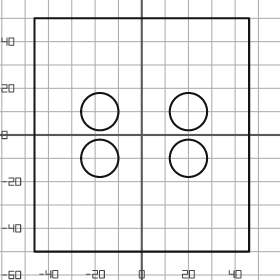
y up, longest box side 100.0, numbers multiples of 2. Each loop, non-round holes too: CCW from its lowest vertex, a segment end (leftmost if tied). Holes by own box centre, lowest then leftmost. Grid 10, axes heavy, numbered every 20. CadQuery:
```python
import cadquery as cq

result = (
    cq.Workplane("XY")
    .moveTo(-46.0, -50.0)
    .lineTo(46.0, -50.0)
    .lineTo(46.0, 50.0)
    .lineTo(-46.0, 50.0)
    .close()
    .moveTo(-18.0, -10.0)
    .circle(8.0)
    .moveTo(20.0, -10.0)
    .circle(8.0)
    .moveTo(-18.0, 10.0)
    .circle(8.0)
    .moveTo(20.0, 10.0)
    .circle(8.0)
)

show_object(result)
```